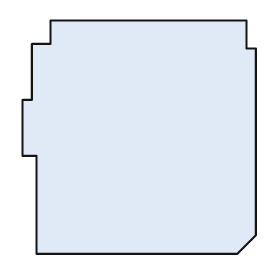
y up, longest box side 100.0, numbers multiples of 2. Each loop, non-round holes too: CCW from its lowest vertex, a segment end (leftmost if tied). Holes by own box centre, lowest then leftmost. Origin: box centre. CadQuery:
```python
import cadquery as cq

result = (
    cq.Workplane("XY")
    .moveTo(-44.0, -50.0)
    .lineTo(42.0, -50.0)
    .lineTo(50.0, -42.0)
    .lineTo(50.0, 38.0)
    .lineTo(46.0, 38.0)
    .lineTo(46.0, 50.0)
    .lineTo(-38.0, 50.0)
    .lineTo(-38.0, 40.0)
    .lineTo(-46.0, 40.0)
    .lineTo(-46.0, 16.0)
    .lineTo(-50.0, 16.0)
    .lineTo(-50.0, -8.0)
    .lineTo(-44.0, -8.0)
    .close()
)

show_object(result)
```